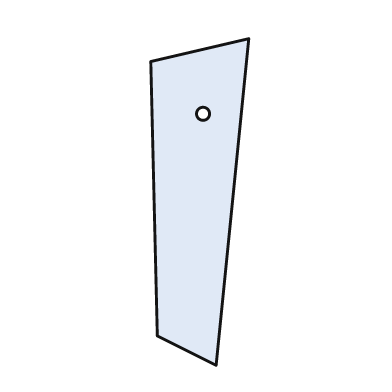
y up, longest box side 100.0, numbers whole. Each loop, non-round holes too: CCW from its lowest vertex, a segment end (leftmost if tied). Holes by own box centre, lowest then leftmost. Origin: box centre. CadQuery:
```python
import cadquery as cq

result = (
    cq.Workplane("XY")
    .moveTo(5.0, -50.0)
    .lineTo(15.0, 50.0)
    .lineTo(-15.0, 43.0)
    .lineTo(-13.0, -41.0)
    .close()
    .moveTo(1.0, 27.0)
    .circle(2.0)
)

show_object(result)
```